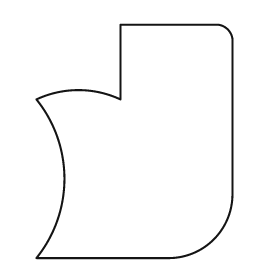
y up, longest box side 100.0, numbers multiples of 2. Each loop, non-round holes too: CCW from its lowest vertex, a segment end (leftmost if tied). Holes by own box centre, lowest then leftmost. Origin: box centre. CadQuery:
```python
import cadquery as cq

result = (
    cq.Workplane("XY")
    .moveTo(-42.0, -50.0)
    .lineTo(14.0, -50.0)
    .threePointArc((34.0, -42.0), (42.0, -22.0))
    .lineTo(42.0, 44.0)
    .threePointArc((40.0, 48.0), (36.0, 50.0))
    .lineTo(-6.0, 50.0)
    .lineTo(-6.0, 18.0)
    .threePointArc((-24.0, 22.0), (-42.0, 18.0))
    .threePointArc((-30.0, -16.0), (-42.0, -50.0))
    .close()
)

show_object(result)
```